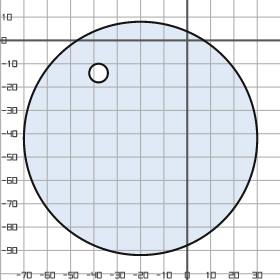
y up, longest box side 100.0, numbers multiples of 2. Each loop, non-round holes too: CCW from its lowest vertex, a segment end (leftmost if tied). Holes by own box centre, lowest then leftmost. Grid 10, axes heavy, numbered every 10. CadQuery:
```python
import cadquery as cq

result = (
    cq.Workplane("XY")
    .moveTo(-20.0, -42.0)
    .circle(50.0)
    .moveTo(-38.0, -14.0)
    .circle(4.0)
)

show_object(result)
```